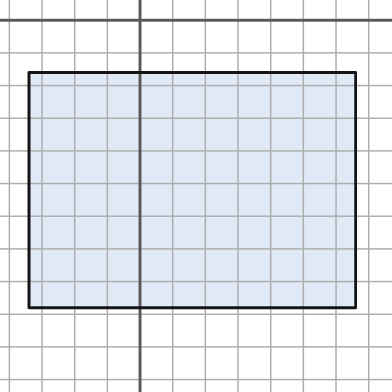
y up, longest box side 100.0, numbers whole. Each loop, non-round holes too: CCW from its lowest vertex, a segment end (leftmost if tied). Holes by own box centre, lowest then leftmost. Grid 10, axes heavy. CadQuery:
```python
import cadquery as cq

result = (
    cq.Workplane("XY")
    .moveTo(-34.0, -88.0)
    .lineTo(66.0, -88.0)
    .lineTo(66.0, -16.0)
    .lineTo(-34.0, -16.0)
    .close()
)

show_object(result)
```